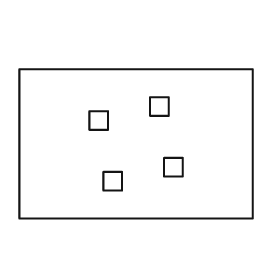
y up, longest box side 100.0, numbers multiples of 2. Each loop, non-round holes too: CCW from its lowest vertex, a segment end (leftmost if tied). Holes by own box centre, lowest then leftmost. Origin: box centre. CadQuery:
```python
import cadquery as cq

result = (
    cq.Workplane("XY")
    .moveTo(-50.0, -32.0)
    .lineTo(50.0, -32.0)
    .lineTo(50.0, 32.0)
    .lineTo(-50.0, 32.0)
    .close()
    .moveTo(-14.0, -20.0)
    .lineTo(-6.0, -20.0)
    .lineTo(-6.0, -12.0)
    .lineTo(-14.0, -12.0)
    .close()
    .moveTo(12.0, -14.0)
    .lineTo(20.0, -14.0)
    .lineTo(20.0, -6.0)
    .lineTo(12.0, -6.0)
    .close()
    .moveTo(-20.0, 6.0)
    .lineTo(-12.0, 6.0)
    .lineTo(-12.0, 14.0)
    .lineTo(-20.0, 14.0)
    .close()
    .moveTo(6.0, 12.0)
    .lineTo(14.0, 12.0)
    .lineTo(14.0, 20.0)
    .lineTo(6.0, 20.0)
    .close()
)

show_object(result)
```